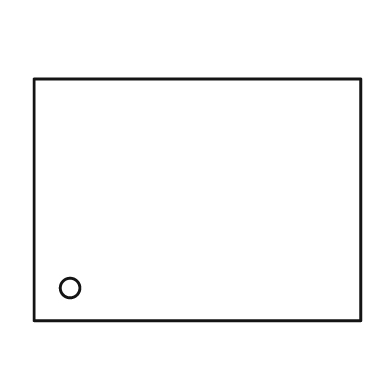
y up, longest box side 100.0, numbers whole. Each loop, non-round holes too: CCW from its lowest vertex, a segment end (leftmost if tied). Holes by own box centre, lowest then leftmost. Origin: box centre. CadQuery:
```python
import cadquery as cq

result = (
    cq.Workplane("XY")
    .moveTo(-50.0, -37.0)
    .lineTo(50.0, -37.0)
    .lineTo(50.0, 37.0)
    .lineTo(-50.0, 37.0)
    .close()
    .moveTo(-39.0, -27.0)
    .circle(3.0)
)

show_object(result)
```